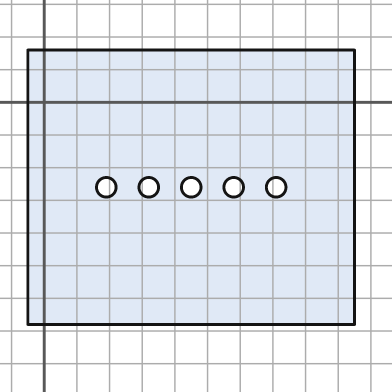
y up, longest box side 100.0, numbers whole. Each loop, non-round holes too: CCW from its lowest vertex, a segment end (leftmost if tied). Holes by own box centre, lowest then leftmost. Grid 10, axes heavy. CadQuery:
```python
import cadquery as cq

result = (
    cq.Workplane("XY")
    .moveTo(-5.0, -68.0)
    .lineTo(95.0, -68.0)
    .lineTo(95.0, 16.0)
    .lineTo(-5.0, 16.0)
    .close()
    .moveTo(19.0, -26.0)
    .circle(3.0)
    .moveTo(32.0, -26.0)
    .circle(3.0)
    .moveTo(45.0, -26.0)
    .circle(3.0)
    .moveTo(58.0, -26.0)
    .circle(3.0)
    .moveTo(71.0, -26.0)
    .circle(3.0)
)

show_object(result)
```